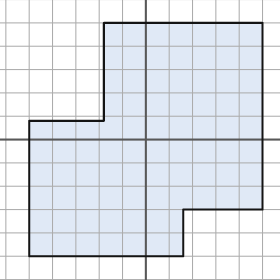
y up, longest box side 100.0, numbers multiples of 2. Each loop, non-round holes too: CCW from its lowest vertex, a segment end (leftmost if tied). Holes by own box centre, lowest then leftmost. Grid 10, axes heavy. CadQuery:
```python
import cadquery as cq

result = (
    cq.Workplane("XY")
    .moveTo(-50.0, -50.0)
    .lineTo(16.0, -50.0)
    .lineTo(16.0, -30.0)
    .lineTo(50.0, -30.0)
    .lineTo(50.0, 50.0)
    .lineTo(-18.0, 50.0)
    .lineTo(-18.0, 8.0)
    .lineTo(-50.0, 8.0)
    .close()
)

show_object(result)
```